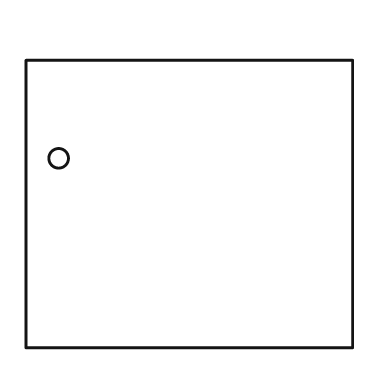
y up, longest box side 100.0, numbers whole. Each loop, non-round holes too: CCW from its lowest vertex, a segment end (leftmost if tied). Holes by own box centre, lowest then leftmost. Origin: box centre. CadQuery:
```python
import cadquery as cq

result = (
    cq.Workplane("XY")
    .moveTo(-50.0, -44.0)
    .lineTo(50.0, -44.0)
    .lineTo(50.0, 44.0)
    .lineTo(-50.0, 44.0)
    .close()
    .moveTo(-40.0, 14.0)
    .circle(3.0)
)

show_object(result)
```